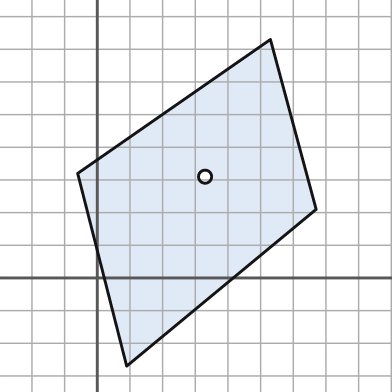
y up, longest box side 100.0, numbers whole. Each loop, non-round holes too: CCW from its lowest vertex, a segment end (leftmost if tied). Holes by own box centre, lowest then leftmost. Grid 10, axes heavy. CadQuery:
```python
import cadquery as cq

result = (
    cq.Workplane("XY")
    .moveTo(9.0, -27.0)
    .lineTo(67.0, 21.0)
    .lineTo(53.0, 73.0)
    .lineTo(-6.0, 32.0)
    .close()
    .moveTo(33.0, 31.0)
    .circle(2.0)
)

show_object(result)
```